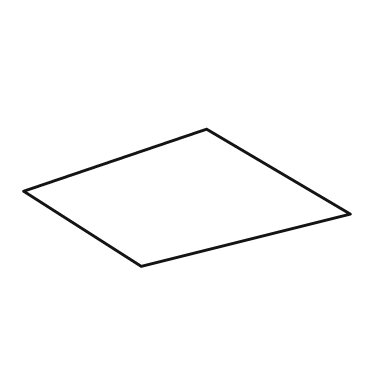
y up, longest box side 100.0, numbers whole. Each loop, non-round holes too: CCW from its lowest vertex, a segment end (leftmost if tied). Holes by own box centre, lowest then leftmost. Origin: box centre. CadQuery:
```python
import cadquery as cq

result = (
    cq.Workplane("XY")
    .moveTo(-14.0, -21.0)
    .lineTo(50.0, -5.0)
    .lineTo(6.0, 21.0)
    .lineTo(-50.0, 2.0)
    .close()
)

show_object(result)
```